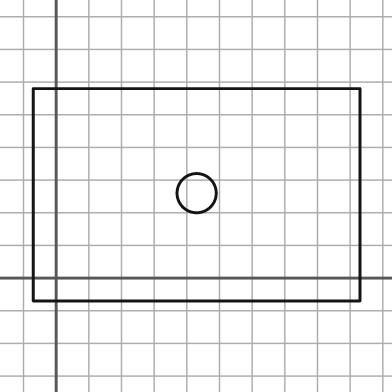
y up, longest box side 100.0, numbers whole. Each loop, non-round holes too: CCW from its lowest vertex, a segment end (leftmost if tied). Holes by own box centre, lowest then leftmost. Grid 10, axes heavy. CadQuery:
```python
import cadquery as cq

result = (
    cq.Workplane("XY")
    .moveTo(-7.0, -7.0)
    .lineTo(93.0, -7.0)
    .lineTo(93.0, 58.0)
    .lineTo(-7.0, 58.0)
    .close()
    .moveTo(43.0, 26.0)
    .circle(6.0)
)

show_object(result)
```